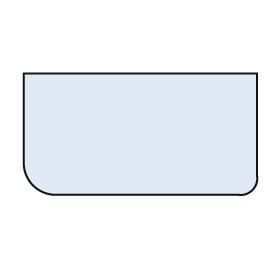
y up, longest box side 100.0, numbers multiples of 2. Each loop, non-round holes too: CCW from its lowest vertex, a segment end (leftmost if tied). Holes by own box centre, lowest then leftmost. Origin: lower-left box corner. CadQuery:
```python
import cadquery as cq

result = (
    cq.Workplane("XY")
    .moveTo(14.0, 0.0)
    .lineTo(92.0, 0.0)
    .threePointArc((98.0, 2.0), (100.0, 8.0))
    .lineTo(100.0, 52.0)
    .lineTo(0.0, 52.0)
    .lineTo(0.0, 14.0)
    .threePointArc((4.0, 4.0), (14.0, 0.0))
    .close()
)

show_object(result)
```